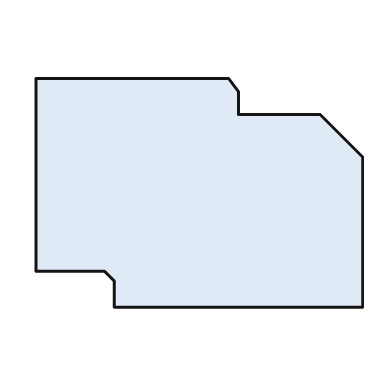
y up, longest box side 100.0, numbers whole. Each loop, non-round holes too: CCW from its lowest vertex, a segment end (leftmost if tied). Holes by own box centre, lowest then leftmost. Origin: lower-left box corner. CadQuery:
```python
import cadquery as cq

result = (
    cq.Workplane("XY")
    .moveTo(24.0, 0.0)
    .lineTo(100.0, 0.0)
    .lineTo(100.0, 46.0)
    .lineTo(87.0, 59.0)
    .lineTo(62.0, 59.0)
    .lineTo(62.0, 66.0)
    .lineTo(59.0, 70.0)
    .lineTo(0.0, 70.0)
    .lineTo(0.0, 11.0)
    .lineTo(21.0, 11.0)
    .lineTo(24.0, 8.0)
    .close()
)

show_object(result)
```